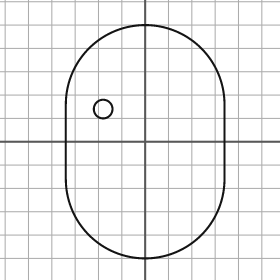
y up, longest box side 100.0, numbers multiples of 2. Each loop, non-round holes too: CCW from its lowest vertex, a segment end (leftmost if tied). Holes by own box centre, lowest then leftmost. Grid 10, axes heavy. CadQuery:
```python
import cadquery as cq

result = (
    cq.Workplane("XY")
    .moveTo(-34.0, -16.0)
    .threePointArc((0.0, -50.0), (34.0, -16.0))
    .lineTo(34.0, 16.0)
    .threePointArc((0.0, 50.0), (-34.0, 16.0))
    .close()
    .moveTo(-18.0, 14.0)
    .circle(4.0)
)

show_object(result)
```